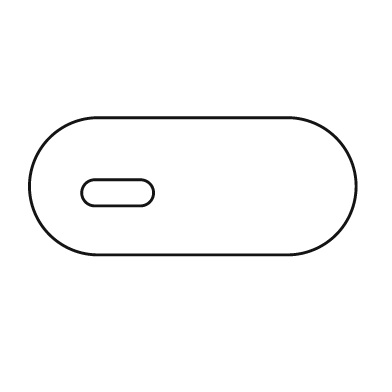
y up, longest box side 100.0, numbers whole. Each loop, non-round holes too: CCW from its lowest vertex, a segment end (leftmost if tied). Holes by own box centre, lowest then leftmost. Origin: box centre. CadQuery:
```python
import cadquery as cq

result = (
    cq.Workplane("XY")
    .moveTo(-29.0, -21.0)
    .lineTo(29.0, -21.0)
    .threePointArc((50.0, 0.0), (29.0, 21.0))
    .lineTo(-29.0, 21.0)
    .threePointArc((-50.0, 0.0), (-29.0, -21.0))
    .close()
    .moveTo(-30.0, -6.0)
    .lineTo(-16.0, -6.0)
    .threePointArc((-12.0, -2.0), (-16.0, 2.0))
    .lineTo(-30.0, 2.0)
    .threePointArc((-34.0, -2.0), (-30.0, -6.0))
    .close()
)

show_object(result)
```